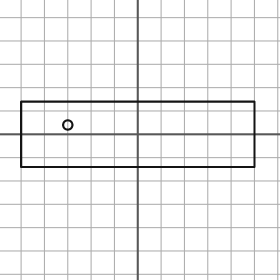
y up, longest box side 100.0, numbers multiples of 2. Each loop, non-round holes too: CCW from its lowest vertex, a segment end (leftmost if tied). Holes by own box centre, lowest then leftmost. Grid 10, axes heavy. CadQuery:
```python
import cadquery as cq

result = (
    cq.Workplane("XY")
    .moveTo(-50.0, -14.0)
    .lineTo(50.0, -14.0)
    .lineTo(50.0, 14.0)
    .lineTo(-50.0, 14.0)
    .close()
    .moveTo(-30.0, 4.0)
    .circle(2.0)
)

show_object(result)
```